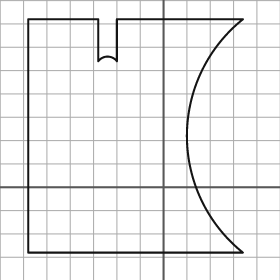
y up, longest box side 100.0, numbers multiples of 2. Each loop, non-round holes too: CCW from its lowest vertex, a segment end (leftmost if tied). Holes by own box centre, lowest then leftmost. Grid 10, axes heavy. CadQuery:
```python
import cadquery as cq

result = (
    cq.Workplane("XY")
    .moveTo(-58.0, -28.0)
    .lineTo(34.0, -28.0)
    .threePointArc((10.0, 22.0), (34.0, 72.0))
    .lineTo(-20.0, 72.0)
    .lineTo(-20.0, 54.0)
    .threePointArc((-24.0, 56.0), (-28.0, 54.0))
    .lineTo(-28.0, 72.0)
    .lineTo(-58.0, 72.0)
    .close()
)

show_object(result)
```